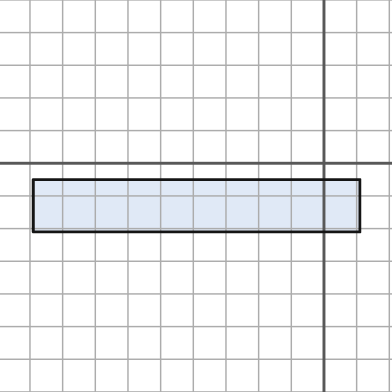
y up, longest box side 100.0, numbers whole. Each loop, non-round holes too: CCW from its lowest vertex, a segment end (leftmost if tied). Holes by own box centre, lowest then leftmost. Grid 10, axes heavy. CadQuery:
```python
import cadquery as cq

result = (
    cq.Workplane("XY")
    .moveTo(-89.0, -21.0)
    .lineTo(11.0, -21.0)
    .lineTo(11.0, -5.0)
    .lineTo(-89.0, -5.0)
    .close()
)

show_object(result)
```